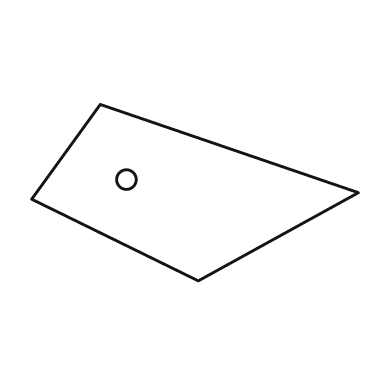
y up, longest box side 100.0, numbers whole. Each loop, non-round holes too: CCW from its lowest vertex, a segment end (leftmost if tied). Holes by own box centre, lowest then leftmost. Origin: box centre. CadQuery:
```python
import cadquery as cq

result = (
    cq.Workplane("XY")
    .moveTo(1.0, -27.0)
    .lineTo(50.0, 0.0)
    .lineTo(-29.0, 27.0)
    .lineTo(-50.0, -2.0)
    .close()
    .moveTo(-21.0, 4.0)
    .circle(3.0)
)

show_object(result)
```